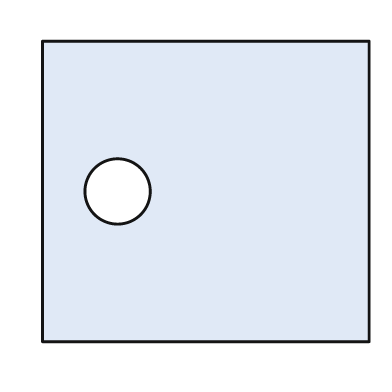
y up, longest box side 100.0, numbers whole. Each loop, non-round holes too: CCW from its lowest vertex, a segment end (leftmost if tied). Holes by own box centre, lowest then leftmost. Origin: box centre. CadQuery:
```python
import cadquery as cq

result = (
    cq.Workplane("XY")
    .moveTo(-50.0, -46.0)
    .lineTo(50.0, -46.0)
    .lineTo(50.0, 46.0)
    .lineTo(-50.0, 46.0)
    .close()
    .moveTo(-27.0, 0.0)
    .circle(10.0)
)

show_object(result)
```